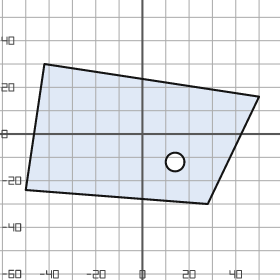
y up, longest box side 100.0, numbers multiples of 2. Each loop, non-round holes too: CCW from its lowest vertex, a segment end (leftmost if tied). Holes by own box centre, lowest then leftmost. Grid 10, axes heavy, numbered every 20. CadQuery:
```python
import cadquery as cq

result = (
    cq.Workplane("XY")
    .moveTo(28.0, -30.0)
    .lineTo(50.0, 16.0)
    .lineTo(-42.0, 30.0)
    .lineTo(-50.0, -24.0)
    .close()
    .moveTo(14.0, -12.0)
    .circle(4.0)
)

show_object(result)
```